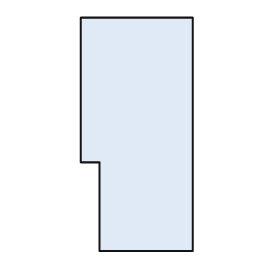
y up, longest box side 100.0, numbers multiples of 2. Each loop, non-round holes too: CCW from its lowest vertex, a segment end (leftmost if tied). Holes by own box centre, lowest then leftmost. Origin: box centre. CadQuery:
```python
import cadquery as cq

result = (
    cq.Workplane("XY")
    .moveTo(-16.0, -50.0)
    .lineTo(24.0, -50.0)
    .lineTo(24.0, 50.0)
    .lineTo(-24.0, 50.0)
    .lineTo(-24.0, -12.0)
    .lineTo(-16.0, -12.0)
    .close()
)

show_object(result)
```